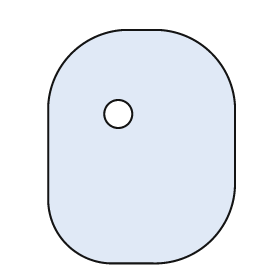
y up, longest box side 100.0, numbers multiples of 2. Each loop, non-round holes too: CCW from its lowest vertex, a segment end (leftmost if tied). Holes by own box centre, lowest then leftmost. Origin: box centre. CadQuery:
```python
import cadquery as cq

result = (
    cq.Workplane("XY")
    .moveTo(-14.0, -50.0)
    .lineTo(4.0, -50.0)
    .threePointArc((30.0, -40.0), (40.0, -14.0))
    .lineTo(40.0, 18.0)
    .threePointArc((30.0, 40.0), (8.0, 50.0))
    .lineTo(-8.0, 50.0)
    .threePointArc((-30.0, 40.0), (-40.0, 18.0))
    .lineTo(-40.0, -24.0)
    .threePointArc((-32.0, -42.0), (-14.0, -50.0))
    .close()
    .moveTo(-10.0, 14.0)
    .circle(6.0)
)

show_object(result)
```